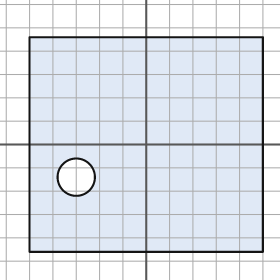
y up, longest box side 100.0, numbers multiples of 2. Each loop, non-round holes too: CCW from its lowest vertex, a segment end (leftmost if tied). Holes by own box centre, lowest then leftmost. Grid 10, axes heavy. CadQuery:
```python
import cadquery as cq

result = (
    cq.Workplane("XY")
    .moveTo(-50.0, -46.0)
    .lineTo(50.0, -46.0)
    .lineTo(50.0, 46.0)
    .lineTo(-50.0, 46.0)
    .close()
    .moveTo(-30.0, -14.0)
    .circle(8.0)
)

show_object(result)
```